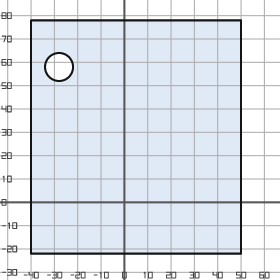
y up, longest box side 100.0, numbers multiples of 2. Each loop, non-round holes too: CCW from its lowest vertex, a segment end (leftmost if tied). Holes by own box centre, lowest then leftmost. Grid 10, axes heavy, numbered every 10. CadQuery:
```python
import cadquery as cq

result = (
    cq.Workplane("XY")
    .moveTo(-40.0, -22.0)
    .lineTo(50.0, -22.0)
    .lineTo(50.0, 78.0)
    .lineTo(-40.0, 78.0)
    .close()
    .moveTo(-28.0, 58.0)
    .circle(6.0)
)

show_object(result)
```